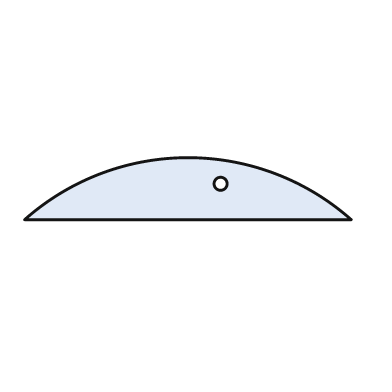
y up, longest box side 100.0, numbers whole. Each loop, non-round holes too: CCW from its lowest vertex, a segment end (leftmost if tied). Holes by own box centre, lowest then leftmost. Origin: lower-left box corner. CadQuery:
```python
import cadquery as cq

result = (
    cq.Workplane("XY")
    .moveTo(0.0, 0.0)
    .lineTo(100.0, 0.0)
    .threePointArc((50.0, 19.0), (0.0, 0.0))
    .close()
    .moveTo(60.0, 11.0)
    .circle(2.0)
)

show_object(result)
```